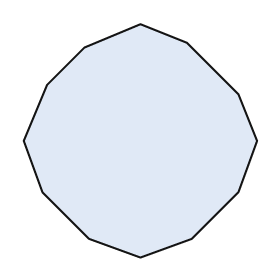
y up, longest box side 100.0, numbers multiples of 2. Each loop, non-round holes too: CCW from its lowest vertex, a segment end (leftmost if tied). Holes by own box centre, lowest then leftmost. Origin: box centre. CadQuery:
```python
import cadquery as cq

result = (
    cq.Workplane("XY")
    .moveTo(0.0, -50.0)
    .lineTo(22.0, -42.0)
    .lineTo(42.0, -22.0)
    .lineTo(50.0, 0.0)
    .lineTo(42.0, 20.0)
    .lineTo(20.0, 42.0)
    .lineTo(0.0, 50.0)
    .lineTo(-24.0, 40.0)
    .lineTo(-40.0, 24.0)
    .lineTo(-50.0, 0.0)
    .lineTo(-42.0, -22.0)
    .lineTo(-22.0, -42.0)
    .close()
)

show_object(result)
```